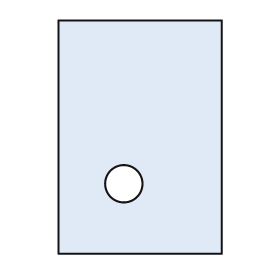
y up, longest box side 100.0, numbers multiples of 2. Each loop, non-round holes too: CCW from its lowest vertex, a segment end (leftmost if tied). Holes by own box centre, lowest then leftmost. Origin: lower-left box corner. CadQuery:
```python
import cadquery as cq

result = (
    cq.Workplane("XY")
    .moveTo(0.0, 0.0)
    .lineTo(70.0, 0.0)
    .lineTo(70.0, 100.0)
    .lineTo(0.0, 100.0)
    .close()
    .moveTo(28.0, 30.0)
    .circle(8.0)
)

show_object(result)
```